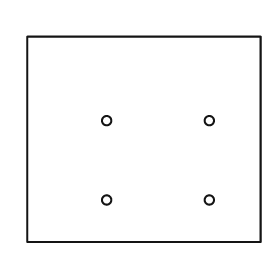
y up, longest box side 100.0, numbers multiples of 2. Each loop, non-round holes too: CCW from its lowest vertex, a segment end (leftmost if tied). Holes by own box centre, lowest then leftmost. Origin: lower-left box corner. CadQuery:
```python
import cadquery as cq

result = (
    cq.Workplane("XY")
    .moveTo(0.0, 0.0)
    .lineTo(100.0, 0.0)
    .lineTo(100.0, 88.0)
    .lineTo(0.0, 88.0)
    .close()
    .moveTo(34.0, 18.0)
    .circle(2.0)
    .moveTo(78.0, 18.0)
    .circle(2.0)
    .moveTo(34.0, 52.0)
    .circle(2.0)
    .moveTo(78.0, 52.0)
    .circle(2.0)
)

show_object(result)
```